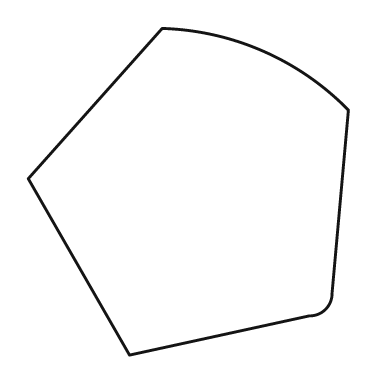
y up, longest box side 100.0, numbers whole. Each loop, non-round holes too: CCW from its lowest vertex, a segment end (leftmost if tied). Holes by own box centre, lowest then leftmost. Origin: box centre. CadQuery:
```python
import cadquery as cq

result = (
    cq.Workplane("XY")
    .moveTo(-18.0, -50.0)
    .lineTo(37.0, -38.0)
    .threePointArc((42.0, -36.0), (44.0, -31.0))
    .lineTo(49.0, 25.0)
    .threePointArc((23.0, 43.0), (-8.0, 50.0))
    .lineTo(-49.0, 4.0)
    .close()
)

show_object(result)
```